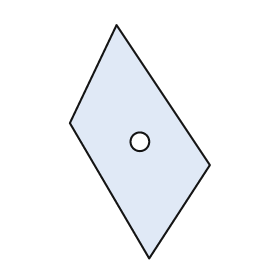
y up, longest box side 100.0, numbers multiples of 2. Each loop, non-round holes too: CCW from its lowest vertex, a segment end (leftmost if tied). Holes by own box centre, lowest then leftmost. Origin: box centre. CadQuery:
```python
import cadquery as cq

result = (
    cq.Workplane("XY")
    .moveTo(4.0, -50.0)
    .lineTo(30.0, -10.0)
    .lineTo(-10.0, 50.0)
    .lineTo(-30.0, 8.0)
    .close()
    .moveTo(0.0, 0.0)
    .circle(4.0)
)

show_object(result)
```